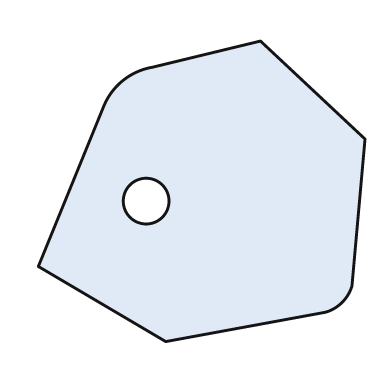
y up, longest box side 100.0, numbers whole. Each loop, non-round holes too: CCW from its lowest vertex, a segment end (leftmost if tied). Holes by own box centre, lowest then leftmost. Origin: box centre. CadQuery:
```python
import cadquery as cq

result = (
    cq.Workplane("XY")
    .moveTo(-11.0, -46.0)
    .lineTo(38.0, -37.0)
    .threePointArc((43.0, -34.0), (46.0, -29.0))
    .lineTo(50.0, 16.0)
    .lineTo(18.0, 46.0)
    .lineTo(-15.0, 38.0)
    .threePointArc((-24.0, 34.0), (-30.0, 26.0))
    .lineTo(-50.0, -23.0)
    .close()
    .moveTo(-17.0, -3.0)
    .circle(7.0)
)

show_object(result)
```